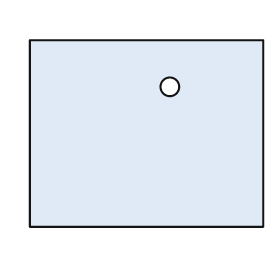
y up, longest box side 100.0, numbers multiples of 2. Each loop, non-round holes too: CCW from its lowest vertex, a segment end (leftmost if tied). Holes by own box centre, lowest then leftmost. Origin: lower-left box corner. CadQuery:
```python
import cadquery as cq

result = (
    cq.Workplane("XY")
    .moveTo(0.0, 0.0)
    .lineTo(100.0, 0.0)
    .lineTo(100.0, 80.0)
    .lineTo(0.0, 80.0)
    .close()
    .moveTo(60.0, 60.0)
    .circle(4.0)
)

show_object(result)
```